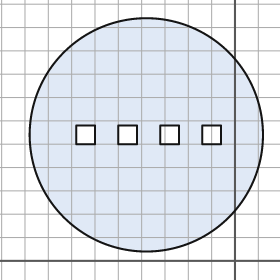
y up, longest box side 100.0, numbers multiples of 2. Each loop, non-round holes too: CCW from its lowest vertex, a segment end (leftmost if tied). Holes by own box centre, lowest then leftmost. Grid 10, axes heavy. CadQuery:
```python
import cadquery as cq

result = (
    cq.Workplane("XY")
    .moveTo(-38.0, 54.0)
    .circle(50.0)
    .moveTo(-68.0, 50.0)
    .lineTo(-60.0, 50.0)
    .lineTo(-60.0, 58.0)
    .lineTo(-68.0, 58.0)
    .close()
    .moveTo(-50.0, 50.0)
    .lineTo(-42.0, 50.0)
    .lineTo(-42.0, 58.0)
    .lineTo(-50.0, 58.0)
    .close()
    .moveTo(-32.0, 50.0)
    .lineTo(-24.0, 50.0)
    .lineTo(-24.0, 58.0)
    .lineTo(-32.0, 58.0)
    .close()
    .moveTo(-14.0, 50.0)
    .lineTo(-6.0, 50.0)
    .lineTo(-6.0, 58.0)
    .lineTo(-14.0, 58.0)
    .close()
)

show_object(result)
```